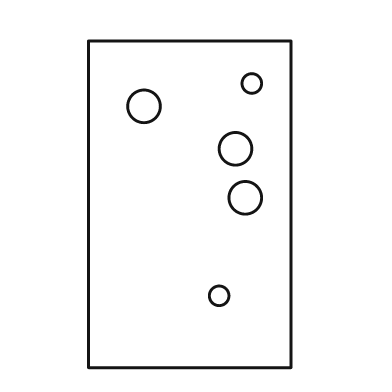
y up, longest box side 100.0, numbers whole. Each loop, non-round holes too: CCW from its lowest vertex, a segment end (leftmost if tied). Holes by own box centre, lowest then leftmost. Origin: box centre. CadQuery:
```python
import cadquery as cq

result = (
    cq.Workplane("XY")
    .moveTo(-31.0, -50.0)
    .lineTo(31.0, -50.0)
    .lineTo(31.0, 50.0)
    .lineTo(-31.0, 50.0)
    .close()
    .moveTo(9.0, -28.0)
    .circle(3.0)
    .moveTo(17.0, 2.0)
    .circle(5.0)
    .moveTo(14.0, 17.0)
    .circle(5.0)
    .moveTo(-14.0, 30.0)
    .circle(5.0)
    .moveTo(19.0, 37.0)
    .circle(3.0)
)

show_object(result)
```